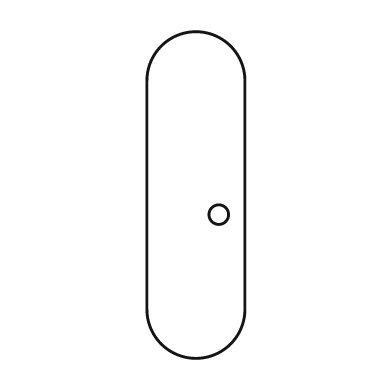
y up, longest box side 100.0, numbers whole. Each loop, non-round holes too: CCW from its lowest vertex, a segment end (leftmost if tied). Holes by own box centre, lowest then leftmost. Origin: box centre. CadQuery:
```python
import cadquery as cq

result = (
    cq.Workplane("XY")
    .moveTo(-15.0, -35.0)
    .threePointArc((0.0, -50.0), (15.0, -35.0))
    .lineTo(15.0, 35.0)
    .threePointArc((0.0, 50.0), (-15.0, 35.0))
    .close()
    .moveTo(7.0, -6.0)
    .circle(3.0)
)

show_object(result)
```